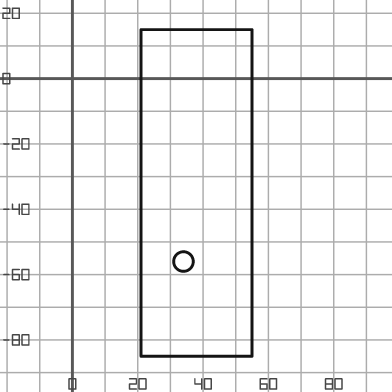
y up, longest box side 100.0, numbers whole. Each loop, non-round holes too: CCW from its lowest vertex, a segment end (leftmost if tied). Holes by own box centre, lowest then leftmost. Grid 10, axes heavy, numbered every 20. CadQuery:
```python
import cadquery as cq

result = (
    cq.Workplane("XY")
    .moveTo(21.0, -85.0)
    .lineTo(55.0, -85.0)
    .lineTo(55.0, 15.0)
    .lineTo(21.0, 15.0)
    .close()
    .moveTo(34.0, -56.0)
    .circle(3.0)
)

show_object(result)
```